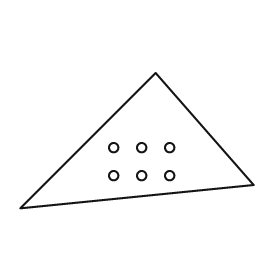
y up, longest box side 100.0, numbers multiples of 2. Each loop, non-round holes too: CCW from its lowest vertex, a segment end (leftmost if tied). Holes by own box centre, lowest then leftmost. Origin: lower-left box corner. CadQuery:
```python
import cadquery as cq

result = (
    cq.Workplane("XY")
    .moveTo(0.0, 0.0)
    .lineTo(100.0, 10.0)
    .lineTo(58.0, 58.0)
    .close()
    .moveTo(40.0, 14.0)
    .circle(2.0)
    .moveTo(52.0, 14.0)
    .circle(2.0)
    .moveTo(64.0, 14.0)
    .circle(2.0)
    .moveTo(40.0, 26.0)
    .circle(2.0)
    .moveTo(52.0, 26.0)
    .circle(2.0)
    .moveTo(64.0, 26.0)
    .circle(2.0)
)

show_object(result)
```